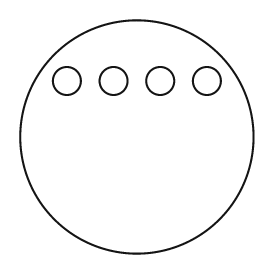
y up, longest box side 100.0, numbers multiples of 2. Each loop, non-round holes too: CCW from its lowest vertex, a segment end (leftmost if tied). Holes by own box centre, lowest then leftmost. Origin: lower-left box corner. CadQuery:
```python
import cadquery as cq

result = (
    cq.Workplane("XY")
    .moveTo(50.0, 50.0)
    .circle(50.0)
    .moveTo(20.0, 74.0)
    .circle(6.0)
    .moveTo(40.0, 74.0)
    .circle(6.0)
    .moveTo(60.0, 74.0)
    .circle(6.0)
    .moveTo(80.0, 74.0)
    .circle(6.0)
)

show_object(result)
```